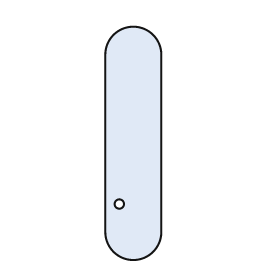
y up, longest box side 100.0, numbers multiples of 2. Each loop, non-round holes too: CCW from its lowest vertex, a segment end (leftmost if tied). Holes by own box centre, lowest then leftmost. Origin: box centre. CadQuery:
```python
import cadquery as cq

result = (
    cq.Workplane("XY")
    .moveTo(-12.0, -38.0)
    .threePointArc((0.0, -50.0), (12.0, -38.0))
    .lineTo(12.0, 38.0)
    .threePointArc((0.0, 50.0), (-12.0, 38.0))
    .close()
    .moveTo(-6.0, -26.0)
    .circle(2.0)
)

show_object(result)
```